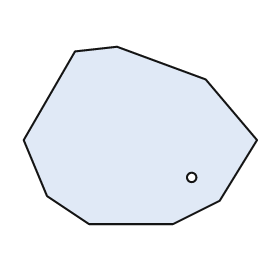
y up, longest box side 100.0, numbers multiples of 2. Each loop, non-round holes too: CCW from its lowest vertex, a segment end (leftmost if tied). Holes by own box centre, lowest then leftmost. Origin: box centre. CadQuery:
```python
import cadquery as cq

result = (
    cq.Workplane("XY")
    .moveTo(-22.0, -38.0)
    .lineTo(14.0, -38.0)
    .lineTo(34.0, -28.0)
    .lineTo(50.0, -2.0)
    .lineTo(28.0, 24.0)
    .lineTo(-10.0, 38.0)
    .lineTo(-28.0, 36.0)
    .lineTo(-50.0, -2.0)
    .lineTo(-40.0, -26.0)
    .close()
    .moveTo(22.0, -18.0)
    .circle(2.0)
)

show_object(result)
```